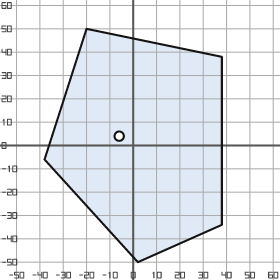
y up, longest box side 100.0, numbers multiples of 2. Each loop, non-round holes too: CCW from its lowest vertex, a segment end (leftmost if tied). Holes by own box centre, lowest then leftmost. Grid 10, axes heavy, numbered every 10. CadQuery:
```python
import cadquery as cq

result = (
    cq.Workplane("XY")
    .moveTo(2.0, -50.0)
    .lineTo(38.0, -34.0)
    .lineTo(38.0, 38.0)
    .lineTo(-20.0, 50.0)
    .lineTo(-38.0, -6.0)
    .close()
    .moveTo(-6.0, 4.0)
    .circle(2.0)
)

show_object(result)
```